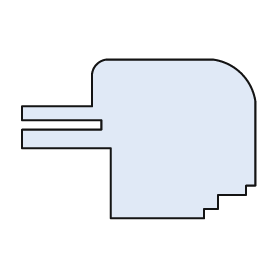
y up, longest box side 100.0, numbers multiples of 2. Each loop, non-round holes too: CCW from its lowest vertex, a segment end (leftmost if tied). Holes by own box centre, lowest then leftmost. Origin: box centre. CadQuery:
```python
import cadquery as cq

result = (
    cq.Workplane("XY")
    .moveTo(-12.0, -34.0)
    .lineTo(28.0, -34.0)
    .lineTo(28.0, -30.0)
    .lineTo(34.0, -30.0)
    .lineTo(34.0, -24.0)
    .lineTo(46.0, -24.0)
    .lineTo(46.0, -20.0)
    .lineTo(50.0, -20.0)
    .lineTo(50.0, 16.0)
    .threePointArc((44.0, 28.0), (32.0, 34.0))
    .lineTo(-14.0, 34.0)
    .threePointArc((-18.0, 32.0), (-20.0, 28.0))
    .lineTo(-20.0, 14.0)
    .lineTo(-50.0, 14.0)
    .lineTo(-50.0, 8.0)
    .lineTo(-16.0, 8.0)
    .lineTo(-16.0, 4.0)
    .lineTo(-50.0, 4.0)
    .lineTo(-50.0, -4.0)
    .lineTo(-12.0, -4.0)
    .close()
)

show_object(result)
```